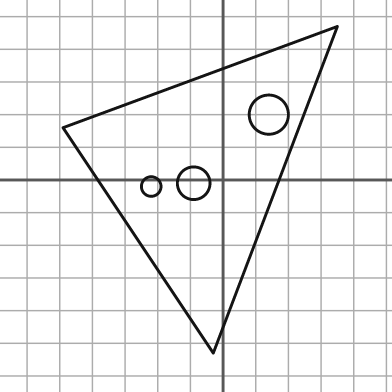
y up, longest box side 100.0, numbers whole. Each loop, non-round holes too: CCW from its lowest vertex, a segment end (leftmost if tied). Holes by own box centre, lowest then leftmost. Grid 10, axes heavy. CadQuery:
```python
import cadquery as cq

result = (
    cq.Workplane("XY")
    .moveTo(-3.0, -53.0)
    .lineTo(35.0, 47.0)
    .lineTo(-49.0, 16.0)
    .close()
    .moveTo(-22.0, -2.0)
    .circle(3.0)
    .moveTo(-9.0, -1.0)
    .circle(5.0)
    .moveTo(14.0, 20.0)
    .circle(6.0)
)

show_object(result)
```